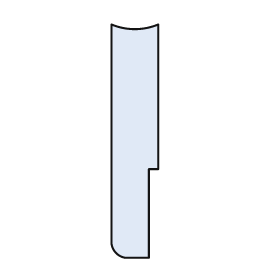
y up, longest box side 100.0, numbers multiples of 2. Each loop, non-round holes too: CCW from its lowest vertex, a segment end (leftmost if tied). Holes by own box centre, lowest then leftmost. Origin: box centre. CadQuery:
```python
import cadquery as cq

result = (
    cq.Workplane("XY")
    .moveTo(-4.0, -50.0)
    .lineTo(6.0, -50.0)
    .lineTo(6.0, -12.0)
    .lineTo(10.0, -12.0)
    .lineTo(10.0, 50.0)
    .threePointArc((0.0, 48.0), (-10.0, 50.0))
    .lineTo(-10.0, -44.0)
    .threePointArc((-8.0, -48.0), (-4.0, -50.0))
    .close()
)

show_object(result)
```